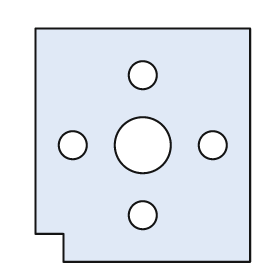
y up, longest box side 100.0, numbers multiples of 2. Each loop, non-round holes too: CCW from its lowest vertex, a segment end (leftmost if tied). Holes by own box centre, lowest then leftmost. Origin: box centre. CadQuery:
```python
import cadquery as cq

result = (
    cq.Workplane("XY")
    .moveTo(-34.0, -50.0)
    .lineTo(46.0, -50.0)
    .lineTo(46.0, 50.0)
    .lineTo(-46.0, 50.0)
    .lineTo(-46.0, -38.0)
    .lineTo(-34.0, -38.0)
    .close()
    .moveTo(0.0, -30.0)
    .circle(6.0)
    .moveTo(-30.0, 0.0)
    .circle(6.0)
    .moveTo(0.0, 0.0)
    .circle(12.0)
    .moveTo(30.0, 0.0)
    .circle(6.0)
    .moveTo(0.0, 30.0)
    .circle(6.0)
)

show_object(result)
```